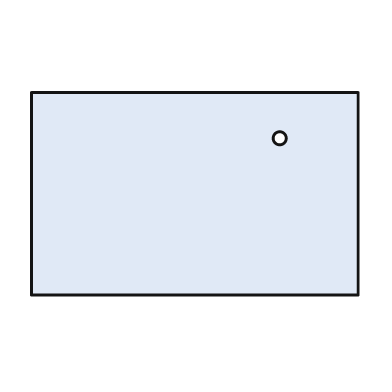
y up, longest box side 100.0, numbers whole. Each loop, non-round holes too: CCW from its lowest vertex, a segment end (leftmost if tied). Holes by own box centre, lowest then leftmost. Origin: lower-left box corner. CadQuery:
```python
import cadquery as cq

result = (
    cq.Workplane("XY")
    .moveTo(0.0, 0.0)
    .lineTo(100.0, 0.0)
    .lineTo(100.0, 62.0)
    .lineTo(0.0, 62.0)
    .close()
    .moveTo(76.0, 48.0)
    .circle(2.0)
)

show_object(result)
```